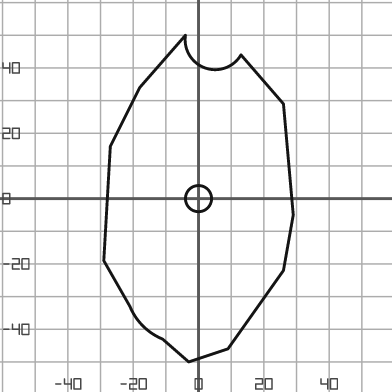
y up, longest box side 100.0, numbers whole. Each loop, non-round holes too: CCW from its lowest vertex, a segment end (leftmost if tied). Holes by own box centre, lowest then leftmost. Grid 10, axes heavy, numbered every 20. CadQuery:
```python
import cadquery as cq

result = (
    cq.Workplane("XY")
    .moveTo(-3.0, -50.0)
    .lineTo(9.0, -46.0)
    .lineTo(26.0, -22.0)
    .lineTo(29.0, -5.0)
    .lineTo(26.0, 29.0)
    .lineTo(13.0, 44.0)
    .threePointArc((2.0, 40.0), (-4.0, 50.0))
    .lineTo(-18.0, 34.0)
    .lineTo(-27.0, 16.0)
    .lineTo(-29.0, -19.0)
    .lineTo(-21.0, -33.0)
    .threePointArc((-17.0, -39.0), (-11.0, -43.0))
    .close()
    .moveTo(0.0, 0.0)
    .circle(4.0)
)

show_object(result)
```